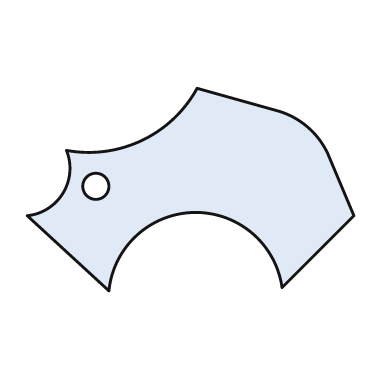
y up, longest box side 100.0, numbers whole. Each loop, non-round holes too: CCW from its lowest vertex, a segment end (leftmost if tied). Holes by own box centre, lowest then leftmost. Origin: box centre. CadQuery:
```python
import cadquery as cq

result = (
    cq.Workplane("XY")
    .moveTo(-25.0, -31.0)
    .threePointArc((1.0, -7.0), (28.0, -30.0))
    .lineTo(50.0, -8.0)
    .lineTo(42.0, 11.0)
    .threePointArc((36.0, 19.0), (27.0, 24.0))
    .lineTo(2.0, 31.0)
    .threePointArc((-15.0, 15.0), (-38.0, 12.0))
    .threePointArc((-39.0, -1.0), (-50.0, -8.0))
    .close()
    .moveTo(-29.0, 1.0)
    .circle(4.0)
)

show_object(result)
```